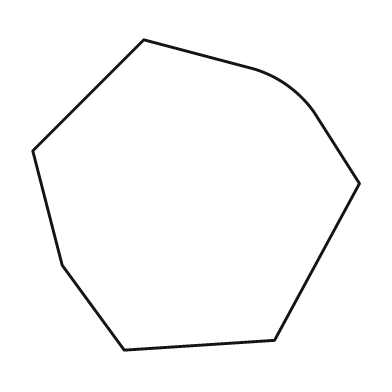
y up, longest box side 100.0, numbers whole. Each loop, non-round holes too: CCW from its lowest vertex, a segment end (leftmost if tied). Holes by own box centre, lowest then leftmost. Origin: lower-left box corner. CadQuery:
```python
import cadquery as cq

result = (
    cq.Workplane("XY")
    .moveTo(28.0, 0.0)
    .lineTo(74.0, 3.0)
    .lineTo(100.0, 51.0)
    .lineTo(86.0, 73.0)
    .threePointArc((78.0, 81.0), (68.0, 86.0))
    .lineTo(34.0, 95.0)
    .lineTo(0.0, 61.0)
    .lineTo(9.0, 26.0)
    .close()
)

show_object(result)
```